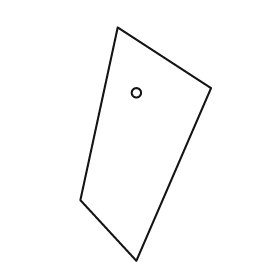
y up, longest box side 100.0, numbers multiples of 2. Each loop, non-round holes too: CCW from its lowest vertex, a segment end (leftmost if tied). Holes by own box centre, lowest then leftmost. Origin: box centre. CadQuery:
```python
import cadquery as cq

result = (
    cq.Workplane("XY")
    .moveTo(-4.0, -50.0)
    .lineTo(28.0, 24.0)
    .lineTo(-12.0, 50.0)
    .lineTo(-28.0, -24.0)
    .close()
    .moveTo(-4.0, 22.0)
    .circle(2.0)
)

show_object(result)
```